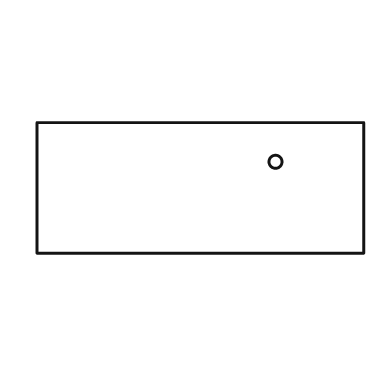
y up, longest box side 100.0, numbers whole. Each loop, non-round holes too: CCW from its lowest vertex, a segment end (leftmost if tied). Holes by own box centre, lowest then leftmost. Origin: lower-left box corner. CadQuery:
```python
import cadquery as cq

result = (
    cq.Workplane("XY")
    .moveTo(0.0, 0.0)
    .lineTo(100.0, 0.0)
    .lineTo(100.0, 40.0)
    .lineTo(0.0, 40.0)
    .close()
    .moveTo(73.0, 28.0)
    .circle(2.0)
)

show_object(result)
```